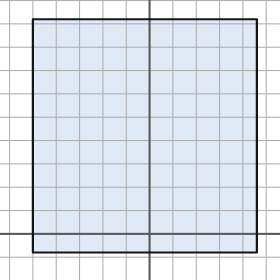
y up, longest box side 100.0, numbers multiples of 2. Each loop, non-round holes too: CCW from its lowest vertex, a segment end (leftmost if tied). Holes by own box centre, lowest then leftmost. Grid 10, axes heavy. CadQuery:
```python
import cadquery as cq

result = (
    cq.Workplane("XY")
    .moveTo(-50.0, -8.0)
    .lineTo(46.0, -8.0)
    .lineTo(46.0, 92.0)
    .lineTo(-50.0, 92.0)
    .close()
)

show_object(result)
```